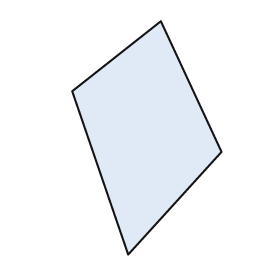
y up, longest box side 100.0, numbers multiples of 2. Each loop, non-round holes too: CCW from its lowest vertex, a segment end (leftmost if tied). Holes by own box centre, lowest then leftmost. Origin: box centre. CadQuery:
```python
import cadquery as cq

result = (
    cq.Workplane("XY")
    .moveTo(-8.0, -50.0)
    .lineTo(32.0, -6.0)
    .lineTo(6.0, 50.0)
    .lineTo(-32.0, 20.0)
    .close()
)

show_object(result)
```